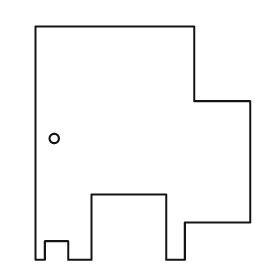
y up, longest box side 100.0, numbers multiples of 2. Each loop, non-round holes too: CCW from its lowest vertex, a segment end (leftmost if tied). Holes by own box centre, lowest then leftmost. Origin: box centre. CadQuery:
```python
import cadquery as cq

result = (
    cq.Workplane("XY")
    .moveTo(-46.0, -50.0)
    .lineTo(-42.0, -50.0)
    .lineTo(-42.0, -42.0)
    .lineTo(-32.0, -42.0)
    .lineTo(-32.0, -50.0)
    .lineTo(-22.0, -50.0)
    .lineTo(-22.0, -22.0)
    .lineTo(10.0, -22.0)
    .lineTo(10.0, -50.0)
    .lineTo(18.0, -50.0)
    .lineTo(18.0, -34.0)
    .lineTo(46.0, -34.0)
    .lineTo(46.0, 18.0)
    .lineTo(22.0, 18.0)
    .lineTo(22.0, 50.0)
    .lineTo(-46.0, 50.0)
    .close()
    .moveTo(-38.0, 2.0)
    .circle(2.0)
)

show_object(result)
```